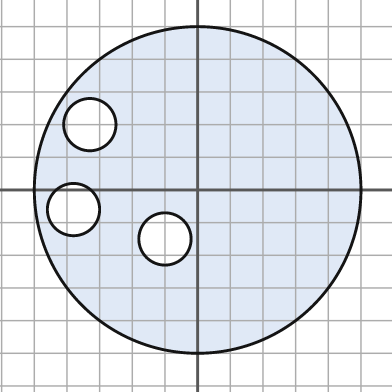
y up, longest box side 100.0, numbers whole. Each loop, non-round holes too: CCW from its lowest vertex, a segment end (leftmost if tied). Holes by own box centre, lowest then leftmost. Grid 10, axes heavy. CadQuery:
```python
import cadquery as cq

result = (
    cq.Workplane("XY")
    .moveTo(0.0, 0.0)
    .circle(50.0)
    .moveTo(-10.0, -15.0)
    .circle(8.0)
    .moveTo(-38.0, -6.0)
    .circle(8.0)
    .moveTo(-33.0, 20.0)
    .circle(8.0)
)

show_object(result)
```